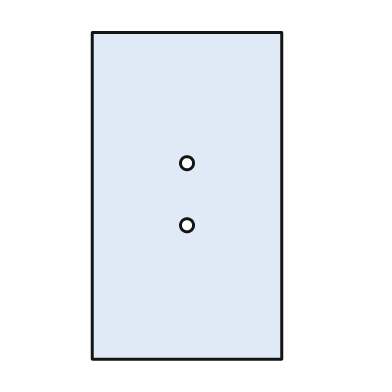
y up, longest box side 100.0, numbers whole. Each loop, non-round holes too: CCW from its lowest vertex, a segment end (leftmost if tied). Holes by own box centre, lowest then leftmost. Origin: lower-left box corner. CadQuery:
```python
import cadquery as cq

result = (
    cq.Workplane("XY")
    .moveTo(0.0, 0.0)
    .lineTo(58.0, 0.0)
    .lineTo(58.0, 100.0)
    .lineTo(0.0, 100.0)
    .close()
    .moveTo(29.0, 41.0)
    .circle(2.0)
    .moveTo(29.0, 60.0)
    .circle(2.0)
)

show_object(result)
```